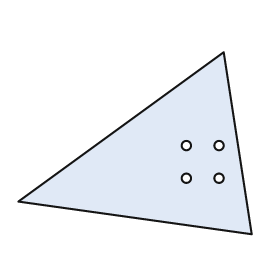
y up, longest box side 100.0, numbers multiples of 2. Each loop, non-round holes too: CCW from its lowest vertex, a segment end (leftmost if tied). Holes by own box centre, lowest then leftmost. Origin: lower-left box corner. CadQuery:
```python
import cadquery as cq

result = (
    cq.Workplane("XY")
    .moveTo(100.0, 0.0)
    .lineTo(88.0, 78.0)
    .lineTo(0.0, 14.0)
    .close()
    .moveTo(72.0, 24.0)
    .circle(2.0)
    .moveTo(86.0, 24.0)
    .circle(2.0)
    .moveTo(72.0, 38.0)
    .circle(2.0)
    .moveTo(86.0, 38.0)
    .circle(2.0)
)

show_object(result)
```